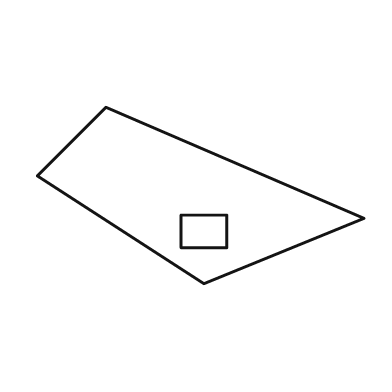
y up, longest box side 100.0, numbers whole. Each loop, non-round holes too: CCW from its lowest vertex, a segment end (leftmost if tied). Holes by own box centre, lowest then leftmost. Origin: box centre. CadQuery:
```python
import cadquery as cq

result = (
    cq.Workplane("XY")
    .moveTo(1.0, -27.0)
    .lineTo(50.0, -7.0)
    .lineTo(-29.0, 27.0)
    .lineTo(-50.0, 6.0)
    .close()
    .moveTo(-6.0, -16.0)
    .lineTo(8.0, -16.0)
    .lineTo(8.0, -6.0)
    .lineTo(-6.0, -6.0)
    .close()
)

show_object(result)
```